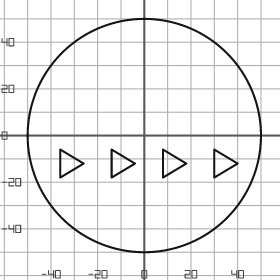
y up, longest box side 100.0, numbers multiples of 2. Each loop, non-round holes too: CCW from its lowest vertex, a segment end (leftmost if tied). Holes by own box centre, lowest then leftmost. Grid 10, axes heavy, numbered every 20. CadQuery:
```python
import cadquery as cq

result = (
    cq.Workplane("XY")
    .moveTo(0.0, 0.0)
    .circle(50.0)
    .moveTo(-36.0, -18.0)
    .lineTo(-26.0, -12.0)
    .lineTo(-36.0, -6.0)
    .close()
    .moveTo(-14.0, -18.0)
    .lineTo(-4.0, -12.0)
    .lineTo(-14.0, -6.0)
    .close()
    .moveTo(8.0, -18.0)
    .lineTo(18.0, -12.0)
    .lineTo(8.0, -6.0)
    .close()
    .moveTo(30.0, -18.0)
    .lineTo(40.0, -12.0)
    .lineTo(30.0, -6.0)
    .close()
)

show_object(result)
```